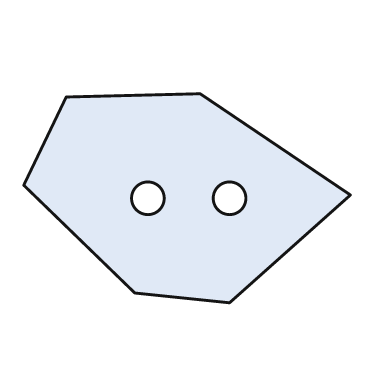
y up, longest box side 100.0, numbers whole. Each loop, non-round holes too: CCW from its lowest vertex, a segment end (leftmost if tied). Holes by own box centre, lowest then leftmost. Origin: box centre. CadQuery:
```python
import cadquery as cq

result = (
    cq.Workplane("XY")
    .moveTo(13.0, -32.0)
    .lineTo(50.0, 1.0)
    .lineTo(4.0, 32.0)
    .lineTo(-37.0, 31.0)
    .lineTo(-50.0, 4.0)
    .lineTo(-16.0, -29.0)
    .close()
    .moveTo(-12.0, 0.0)
    .circle(5.0)
    .moveTo(13.0, 0.0)
    .circle(5.0)
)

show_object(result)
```